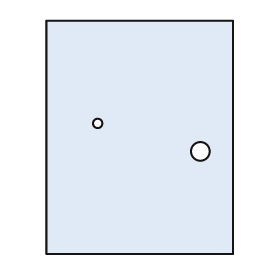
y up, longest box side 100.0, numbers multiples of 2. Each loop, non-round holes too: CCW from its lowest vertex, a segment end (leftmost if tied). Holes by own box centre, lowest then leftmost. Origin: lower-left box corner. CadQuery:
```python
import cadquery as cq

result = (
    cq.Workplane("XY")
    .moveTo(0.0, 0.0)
    .lineTo(80.0, 0.0)
    .lineTo(80.0, 100.0)
    .lineTo(0.0, 100.0)
    .close()
    .moveTo(66.0, 44.0)
    .circle(4.0)
    .moveTo(22.0, 56.0)
    .circle(2.0)
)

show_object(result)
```